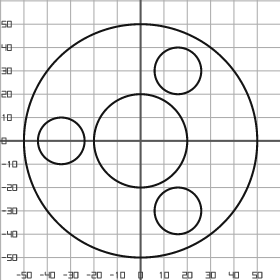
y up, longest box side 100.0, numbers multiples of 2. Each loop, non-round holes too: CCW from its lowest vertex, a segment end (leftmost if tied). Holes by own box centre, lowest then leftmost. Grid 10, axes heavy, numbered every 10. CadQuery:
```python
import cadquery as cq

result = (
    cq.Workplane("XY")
    .moveTo(0.0, 0.0)
    .circle(50.0)
    .moveTo(16.0, -30.0)
    .circle(10.0)
    .moveTo(-34.0, 0.0)
    .circle(10.0)
    .moveTo(0.0, 0.0)
    .circle(20.0)
    .moveTo(16.0, 30.0)
    .circle(10.0)
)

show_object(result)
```